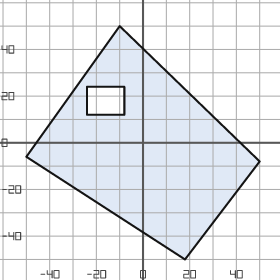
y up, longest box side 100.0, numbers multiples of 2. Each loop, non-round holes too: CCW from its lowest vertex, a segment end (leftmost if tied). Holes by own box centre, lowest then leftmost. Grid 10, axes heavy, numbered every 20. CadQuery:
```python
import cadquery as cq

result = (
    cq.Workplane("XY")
    .moveTo(18.0, -50.0)
    .lineTo(50.0, -8.0)
    .lineTo(-10.0, 50.0)
    .lineTo(-50.0, -6.0)
    .close()
    .moveTo(-24.0, 12.0)
    .lineTo(-8.0, 12.0)
    .lineTo(-8.0, 24.0)
    .lineTo(-24.0, 24.0)
    .close()
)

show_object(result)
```